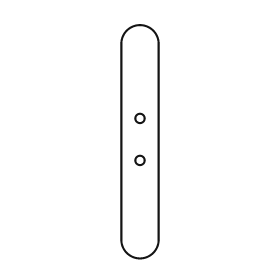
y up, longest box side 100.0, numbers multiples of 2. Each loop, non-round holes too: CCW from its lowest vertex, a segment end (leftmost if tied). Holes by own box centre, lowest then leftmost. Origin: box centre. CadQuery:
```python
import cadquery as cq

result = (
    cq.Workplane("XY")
    .moveTo(-8.0, -42.0)
    .threePointArc((0.0, -50.0), (8.0, -42.0))
    .lineTo(8.0, 42.0)
    .threePointArc((0.0, 50.0), (-8.0, 42.0))
    .close()
    .moveTo(0.0, -8.0)
    .circle(2.0)
    .moveTo(0.0, 10.0)
    .circle(2.0)
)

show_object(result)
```